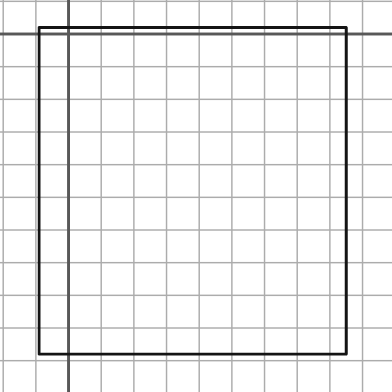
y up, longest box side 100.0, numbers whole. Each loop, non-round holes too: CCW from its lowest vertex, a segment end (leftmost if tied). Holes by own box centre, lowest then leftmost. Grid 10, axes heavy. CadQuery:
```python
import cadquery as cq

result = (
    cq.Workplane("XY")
    .moveTo(-9.0, -98.0)
    .lineTo(85.0, -98.0)
    .lineTo(85.0, 2.0)
    .lineTo(-9.0, 2.0)
    .close()
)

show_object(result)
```